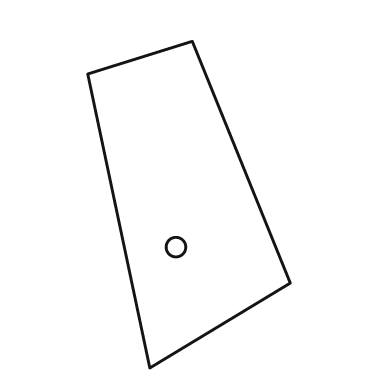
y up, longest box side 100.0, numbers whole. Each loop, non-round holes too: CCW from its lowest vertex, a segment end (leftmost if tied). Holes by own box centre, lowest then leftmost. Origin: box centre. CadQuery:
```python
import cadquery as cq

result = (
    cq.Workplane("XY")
    .moveTo(-12.0, -50.0)
    .lineTo(31.0, -24.0)
    .lineTo(1.0, 50.0)
    .lineTo(-31.0, 40.0)
    .close()
    .moveTo(-4.0, -13.0)
    .circle(3.0)
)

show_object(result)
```